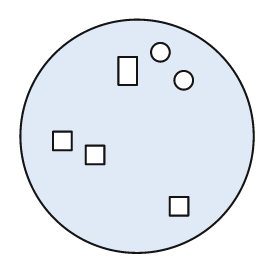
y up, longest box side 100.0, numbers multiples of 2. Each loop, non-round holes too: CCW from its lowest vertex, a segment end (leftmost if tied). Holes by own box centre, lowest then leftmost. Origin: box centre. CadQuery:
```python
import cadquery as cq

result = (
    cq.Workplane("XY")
    .moveTo(0.0, 0.0)
    .circle(50.0)
    .moveTo(14.0, -34.0)
    .lineTo(22.0, -34.0)
    .lineTo(22.0, -26.0)
    .lineTo(14.0, -26.0)
    .close()
    .moveTo(-22.0, -12.0)
    .lineTo(-14.0, -12.0)
    .lineTo(-14.0, -4.0)
    .lineTo(-22.0, -4.0)
    .close()
    .moveTo(-36.0, -6.0)
    .lineTo(-28.0, -6.0)
    .lineTo(-28.0, 2.0)
    .lineTo(-36.0, 2.0)
    .close()
    .moveTo(20.0, 24.0)
    .circle(4.0)
    .moveTo(-8.0, 22.0)
    .lineTo(0.0, 22.0)
    .lineTo(0.0, 34.0)
    .lineTo(-8.0, 34.0)
    .close()
    .moveTo(10.0, 36.0)
    .circle(4.0)
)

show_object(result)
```